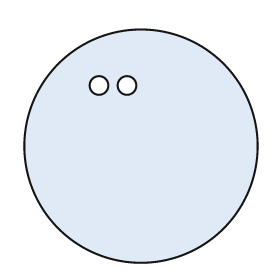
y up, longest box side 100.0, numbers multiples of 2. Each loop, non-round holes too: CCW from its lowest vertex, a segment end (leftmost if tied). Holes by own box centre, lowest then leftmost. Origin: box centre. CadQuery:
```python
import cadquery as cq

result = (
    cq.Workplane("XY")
    .moveTo(0.0, 0.0)
    .circle(50.0)
    .moveTo(-18.0, 26.0)
    .circle(4.0)
    .moveTo(-6.0, 26.0)
    .circle(4.0)
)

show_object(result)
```